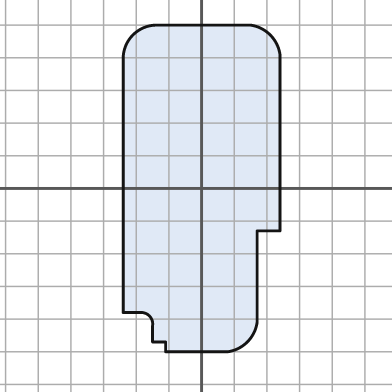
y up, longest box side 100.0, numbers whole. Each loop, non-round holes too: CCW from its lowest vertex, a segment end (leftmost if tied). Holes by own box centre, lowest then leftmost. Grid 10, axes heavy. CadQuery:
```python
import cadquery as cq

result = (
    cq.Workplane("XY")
    .moveTo(-11.0, -50.0)
    .lineTo(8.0, -50.0)
    .threePointArc((14.0, -47.0), (17.0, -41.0))
    .lineTo(17.0, -13.0)
    .lineTo(24.0, -13.0)
    .lineTo(24.0, 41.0)
    .threePointArc((21.0, 47.0), (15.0, 50.0))
    .lineTo(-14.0, 50.0)
    .threePointArc((-21.0, 47.0), (-24.0, 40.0))
    .lineTo(-24.0, -38.0)
    .lineTo(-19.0, -38.0)
    .threePointArc((-16.0, -39.0), (-15.0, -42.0))
    .lineTo(-15.0, -47.0)
    .lineTo(-11.0, -47.0)
    .close()
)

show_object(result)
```